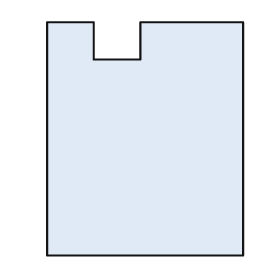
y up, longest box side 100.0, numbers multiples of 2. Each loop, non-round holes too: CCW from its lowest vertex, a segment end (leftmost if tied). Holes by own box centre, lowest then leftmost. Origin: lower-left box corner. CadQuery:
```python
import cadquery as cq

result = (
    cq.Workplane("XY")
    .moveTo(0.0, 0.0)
    .lineTo(84.0, 0.0)
    .lineTo(84.0, 100.0)
    .lineTo(40.0, 100.0)
    .lineTo(40.0, 84.0)
    .lineTo(20.0, 84.0)
    .lineTo(20.0, 100.0)
    .lineTo(0.0, 100.0)
    .close()
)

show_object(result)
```